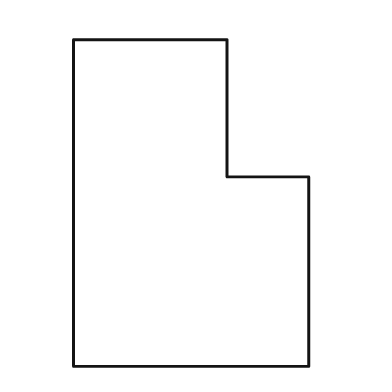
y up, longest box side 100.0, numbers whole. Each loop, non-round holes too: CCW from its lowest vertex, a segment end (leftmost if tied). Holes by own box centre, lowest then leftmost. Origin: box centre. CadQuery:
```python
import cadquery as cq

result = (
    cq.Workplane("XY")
    .moveTo(-36.0, -50.0)
    .lineTo(36.0, -50.0)
    .lineTo(36.0, 8.0)
    .lineTo(11.0, 8.0)
    .lineTo(11.0, 50.0)
    .lineTo(-36.0, 50.0)
    .close()
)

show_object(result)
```